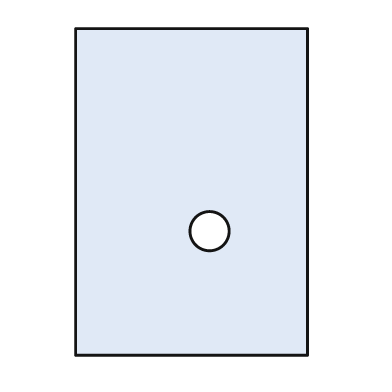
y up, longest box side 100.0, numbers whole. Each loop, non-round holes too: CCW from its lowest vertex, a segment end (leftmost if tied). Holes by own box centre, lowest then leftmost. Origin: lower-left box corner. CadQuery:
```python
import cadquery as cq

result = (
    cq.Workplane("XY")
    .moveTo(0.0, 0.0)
    .lineTo(71.0, 0.0)
    .lineTo(71.0, 100.0)
    .lineTo(0.0, 100.0)
    .close()
    .moveTo(41.0, 38.0)
    .circle(6.0)
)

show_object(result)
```